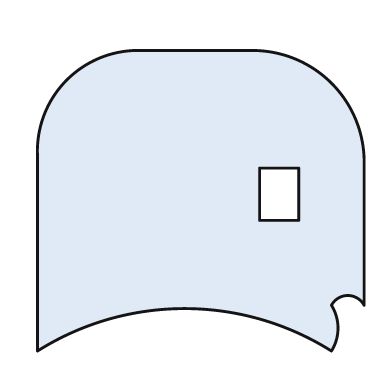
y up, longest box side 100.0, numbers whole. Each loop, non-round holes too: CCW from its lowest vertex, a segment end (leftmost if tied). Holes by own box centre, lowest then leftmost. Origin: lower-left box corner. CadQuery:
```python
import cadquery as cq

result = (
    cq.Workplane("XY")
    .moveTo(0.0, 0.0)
    .threePointArc((45.0, 13.0), (90.0, 0.0))
    .threePointArc((92.0, 7.0), (90.0, 14.0))
    .threePointArc((95.0, 17.0), (100.0, 14.0))
    .lineTo(100.0, 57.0)
    .threePointArc((90.0, 82.0), (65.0, 92.0))
    .lineTo(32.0, 92.0)
    .threePointArc((9.0, 83.0), (0.0, 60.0))
    .close()
    .moveTo(68.0, 40.0)
    .lineTo(80.0, 40.0)
    .lineTo(80.0, 56.0)
    .lineTo(68.0, 56.0)
    .close()
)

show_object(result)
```